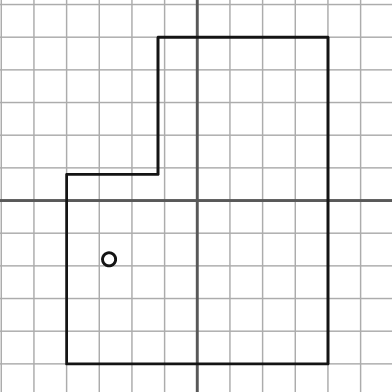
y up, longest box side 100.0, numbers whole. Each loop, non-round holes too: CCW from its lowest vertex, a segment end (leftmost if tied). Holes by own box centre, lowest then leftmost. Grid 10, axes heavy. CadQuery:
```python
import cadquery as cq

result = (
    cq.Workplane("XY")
    .moveTo(-40.0, -50.0)
    .lineTo(40.0, -50.0)
    .lineTo(40.0, 50.0)
    .lineTo(-12.0, 50.0)
    .lineTo(-12.0, 8.0)
    .lineTo(-40.0, 8.0)
    .close()
    .moveTo(-27.0, -18.0)
    .circle(2.0)
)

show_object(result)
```